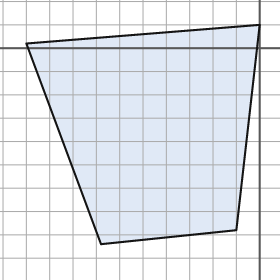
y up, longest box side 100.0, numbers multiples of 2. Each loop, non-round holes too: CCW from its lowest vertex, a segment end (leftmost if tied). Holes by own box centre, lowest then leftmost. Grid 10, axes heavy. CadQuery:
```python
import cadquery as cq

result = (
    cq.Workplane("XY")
    .moveTo(-68.0, -84.0)
    .lineTo(-10.0, -78.0)
    .lineTo(0.0, 10.0)
    .lineTo(-100.0, 2.0)
    .close()
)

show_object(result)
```